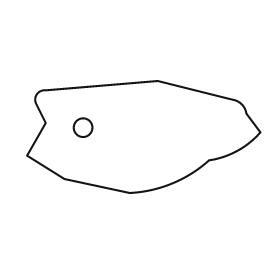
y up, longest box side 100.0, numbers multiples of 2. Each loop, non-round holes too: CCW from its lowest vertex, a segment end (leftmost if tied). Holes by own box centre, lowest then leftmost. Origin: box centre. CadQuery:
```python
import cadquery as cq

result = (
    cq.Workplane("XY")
    .moveTo(-6.0, -24.0)
    .threePointArc((12.0, -20.0), (28.0, -10.0))
    .threePointArc((40.0, -6.0), (50.0, 2.0))
    .lineTo(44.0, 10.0)
    .threePointArc((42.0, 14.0), (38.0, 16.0))
    .lineTo(6.0, 24.0)
    .lineTo(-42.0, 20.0)
    .threePointArc((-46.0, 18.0), (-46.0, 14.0))
    .lineTo(-42.0, 6.0)
    .lineTo(-50.0, -8.0)
    .lineTo(-34.0, -18.0)
    .close()
    .moveTo(-26.0, 4.0)
    .circle(4.0)
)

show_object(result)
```